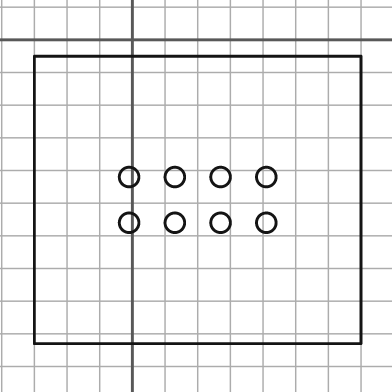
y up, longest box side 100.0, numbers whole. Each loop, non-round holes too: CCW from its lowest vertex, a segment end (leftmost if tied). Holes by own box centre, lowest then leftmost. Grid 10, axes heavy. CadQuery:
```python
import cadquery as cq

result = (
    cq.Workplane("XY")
    .moveTo(-30.0, -93.0)
    .lineTo(70.0, -93.0)
    .lineTo(70.0, -5.0)
    .lineTo(-30.0, -5.0)
    .close()
    .moveTo(-1.0, -56.0)
    .circle(3.0)
    .moveTo(13.0, -56.0)
    .circle(3.0)
    .moveTo(27.0, -56.0)
    .circle(3.0)
    .moveTo(41.0, -56.0)
    .circle(3.0)
    .moveTo(-1.0, -42.0)
    .circle(3.0)
    .moveTo(13.0, -42.0)
    .circle(3.0)
    .moveTo(27.0, -42.0)
    .circle(3.0)
    .moveTo(41.0, -42.0)
    .circle(3.0)
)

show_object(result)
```